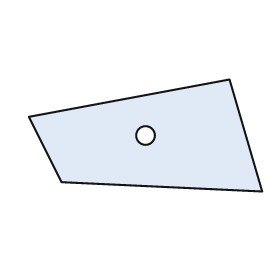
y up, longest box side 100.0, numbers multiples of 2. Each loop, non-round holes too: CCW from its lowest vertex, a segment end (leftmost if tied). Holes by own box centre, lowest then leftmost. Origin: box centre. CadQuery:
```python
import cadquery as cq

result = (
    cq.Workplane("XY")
    .moveTo(50.0, -24.0)
    .lineTo(36.0, 24.0)
    .lineTo(-50.0, 8.0)
    .lineTo(-36.0, -20.0)
    .close()
    .moveTo(0.0, 0.0)
    .circle(4.0)
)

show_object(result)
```